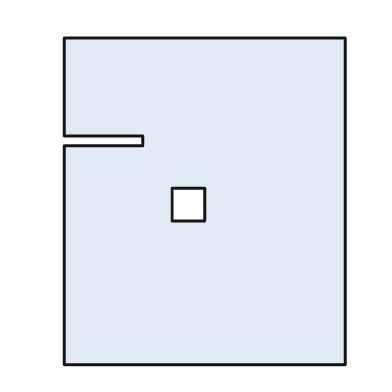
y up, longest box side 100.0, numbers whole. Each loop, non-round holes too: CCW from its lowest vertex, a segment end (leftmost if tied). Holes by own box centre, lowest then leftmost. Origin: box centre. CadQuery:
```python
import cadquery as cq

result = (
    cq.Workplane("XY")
    .moveTo(-43.0, -50.0)
    .lineTo(43.0, -50.0)
    .lineTo(43.0, 50.0)
    .lineTo(-43.0, 50.0)
    .lineTo(-43.0, 20.0)
    .lineTo(-19.0, 20.0)
    .lineTo(-19.0, 17.0)
    .lineTo(-43.0, 17.0)
    .close()
    .moveTo(-10.0, -6.0)
    .lineTo(0.0, -6.0)
    .lineTo(0.0, 4.0)
    .lineTo(-10.0, 4.0)
    .close()
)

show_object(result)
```